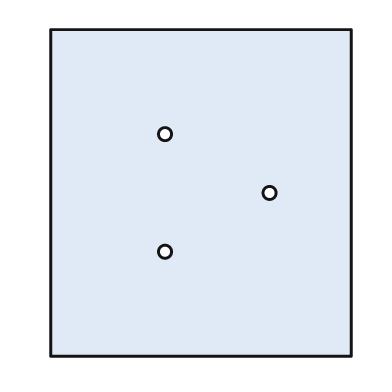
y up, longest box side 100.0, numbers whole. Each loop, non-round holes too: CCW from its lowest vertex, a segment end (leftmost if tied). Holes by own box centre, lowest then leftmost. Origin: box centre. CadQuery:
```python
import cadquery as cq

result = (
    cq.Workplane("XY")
    .moveTo(-46.0, -50.0)
    .lineTo(46.0, -50.0)
    .lineTo(46.0, 50.0)
    .lineTo(-46.0, 50.0)
    .close()
    .moveTo(-11.0, -18.0)
    .circle(2.0)
    .moveTo(21.0, 0.0)
    .circle(2.0)
    .moveTo(-11.0, 18.0)
    .circle(2.0)
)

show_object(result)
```